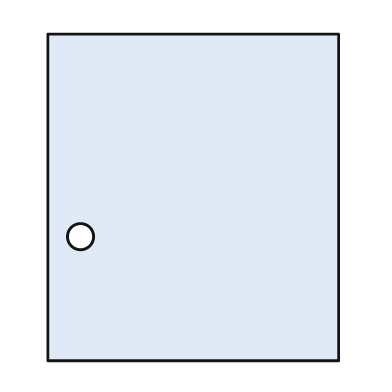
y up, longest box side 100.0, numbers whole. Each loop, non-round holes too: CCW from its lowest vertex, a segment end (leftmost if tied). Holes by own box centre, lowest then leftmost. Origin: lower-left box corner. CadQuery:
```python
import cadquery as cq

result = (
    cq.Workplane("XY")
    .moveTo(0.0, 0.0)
    .lineTo(89.0, 0.0)
    .lineTo(89.0, 100.0)
    .lineTo(0.0, 100.0)
    .close()
    .moveTo(10.0, 38.0)
    .circle(4.0)
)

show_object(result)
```